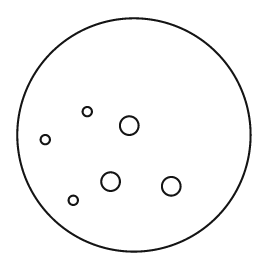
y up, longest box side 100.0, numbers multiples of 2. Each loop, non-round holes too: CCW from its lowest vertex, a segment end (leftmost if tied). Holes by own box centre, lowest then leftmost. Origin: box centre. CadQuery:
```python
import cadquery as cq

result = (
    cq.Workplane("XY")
    .moveTo(0.0, 0.0)
    .circle(50.0)
    .moveTo(-26.0, -28.0)
    .circle(2.0)
    .moveTo(16.0, -22.0)
    .circle(4.0)
    .moveTo(-10.0, -20.0)
    .circle(4.0)
    .moveTo(-38.0, -2.0)
    .circle(2.0)
    .moveTo(-2.0, 4.0)
    .circle(4.0)
    .moveTo(-20.0, 10.0)
    .circle(2.0)
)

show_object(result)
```